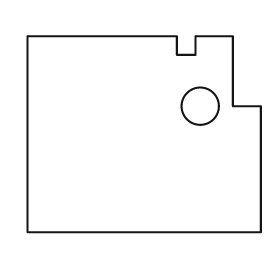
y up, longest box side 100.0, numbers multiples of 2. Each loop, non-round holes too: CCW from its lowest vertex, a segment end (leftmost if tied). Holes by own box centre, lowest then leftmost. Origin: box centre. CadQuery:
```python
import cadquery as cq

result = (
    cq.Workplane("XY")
    .moveTo(-50.0, -42.0)
    .lineTo(50.0, -42.0)
    .lineTo(50.0, 12.0)
    .lineTo(38.0, 12.0)
    .lineTo(38.0, 42.0)
    .lineTo(22.0, 42.0)
    .lineTo(22.0, 34.0)
    .lineTo(14.0, 34.0)
    .lineTo(14.0, 42.0)
    .lineTo(-50.0, 42.0)
    .close()
    .moveTo(24.0, 12.0)
    .circle(8.0)
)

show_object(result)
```